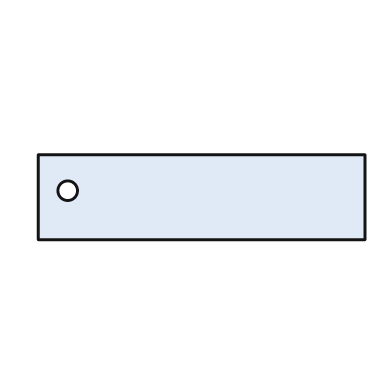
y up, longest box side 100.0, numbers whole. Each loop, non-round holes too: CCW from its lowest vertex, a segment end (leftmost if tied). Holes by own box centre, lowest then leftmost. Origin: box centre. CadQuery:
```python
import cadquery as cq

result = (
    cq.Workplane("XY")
    .moveTo(-50.0, -13.0)
    .lineTo(50.0, -13.0)
    .lineTo(50.0, 13.0)
    .lineTo(-50.0, 13.0)
    .close()
    .moveTo(-41.0, 2.0)
    .circle(3.0)
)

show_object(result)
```